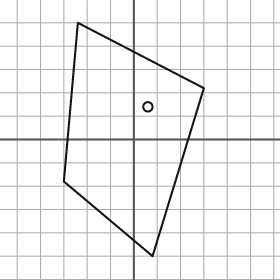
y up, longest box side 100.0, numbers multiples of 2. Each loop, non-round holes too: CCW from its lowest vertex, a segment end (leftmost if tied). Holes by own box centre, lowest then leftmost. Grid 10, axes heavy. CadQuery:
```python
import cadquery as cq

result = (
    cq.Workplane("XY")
    .moveTo(8.0, -50.0)
    .lineTo(30.0, 22.0)
    .lineTo(-24.0, 50.0)
    .lineTo(-30.0, -18.0)
    .close()
    .moveTo(6.0, 14.0)
    .circle(2.0)
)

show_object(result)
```